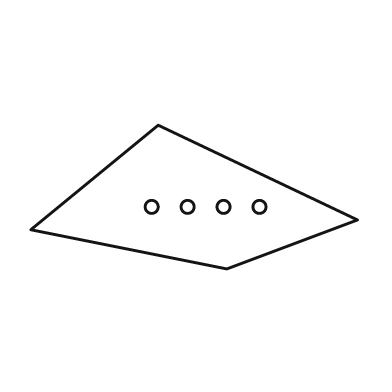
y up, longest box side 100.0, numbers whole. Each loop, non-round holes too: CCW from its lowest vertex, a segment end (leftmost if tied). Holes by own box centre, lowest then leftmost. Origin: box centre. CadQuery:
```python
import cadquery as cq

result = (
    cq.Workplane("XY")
    .moveTo(10.0, -22.0)
    .lineTo(50.0, -7.0)
    .lineTo(-11.0, 22.0)
    .lineTo(-50.0, -10.0)
    .close()
    .moveTo(-13.0, -3.0)
    .circle(2.0)
    .moveTo(-2.0, -3.0)
    .circle(2.0)
    .moveTo(9.0, -3.0)
    .circle(2.0)
    .moveTo(20.0, -3.0)
    .circle(2.0)
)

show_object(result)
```